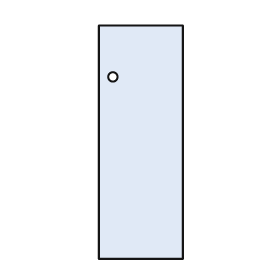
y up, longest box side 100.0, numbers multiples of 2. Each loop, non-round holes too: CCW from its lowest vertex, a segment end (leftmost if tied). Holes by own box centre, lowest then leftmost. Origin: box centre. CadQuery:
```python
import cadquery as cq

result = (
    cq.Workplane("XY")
    .moveTo(-18.0, -50.0)
    .lineTo(18.0, -50.0)
    .lineTo(18.0, 50.0)
    .lineTo(-18.0, 50.0)
    .close()
    .moveTo(-12.0, 28.0)
    .circle(2.0)
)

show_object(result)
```